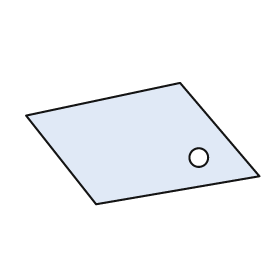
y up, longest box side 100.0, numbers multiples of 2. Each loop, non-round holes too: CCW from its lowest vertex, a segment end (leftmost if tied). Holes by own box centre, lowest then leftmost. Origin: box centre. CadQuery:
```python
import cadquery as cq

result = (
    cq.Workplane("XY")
    .moveTo(-20.0, -26.0)
    .lineTo(50.0, -14.0)
    .lineTo(16.0, 26.0)
    .lineTo(-50.0, 12.0)
    .close()
    .moveTo(24.0, -6.0)
    .circle(4.0)
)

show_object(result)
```